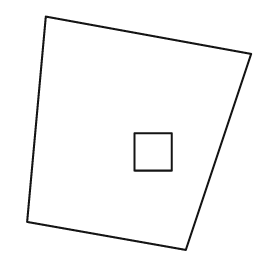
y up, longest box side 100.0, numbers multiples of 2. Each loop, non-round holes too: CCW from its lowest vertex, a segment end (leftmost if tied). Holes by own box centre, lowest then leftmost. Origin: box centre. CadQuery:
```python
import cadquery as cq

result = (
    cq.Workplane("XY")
    .moveTo(20.0, -50.0)
    .lineTo(48.0, 34.0)
    .lineTo(-40.0, 50.0)
    .lineTo(-48.0, -38.0)
    .close()
    .moveTo(-2.0, -16.0)
    .lineTo(14.0, -16.0)
    .lineTo(14.0, 0.0)
    .lineTo(-2.0, 0.0)
    .close()
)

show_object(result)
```